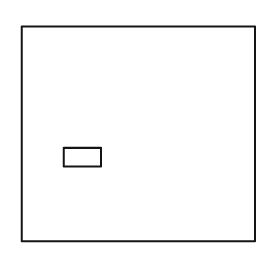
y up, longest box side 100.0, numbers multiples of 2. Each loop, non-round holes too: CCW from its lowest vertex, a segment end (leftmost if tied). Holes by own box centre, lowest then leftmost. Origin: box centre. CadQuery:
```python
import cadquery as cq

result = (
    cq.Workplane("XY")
    .moveTo(-50.0, -46.0)
    .lineTo(50.0, -46.0)
    .lineTo(50.0, 46.0)
    .lineTo(-50.0, 46.0)
    .close()
    .moveTo(-32.0, -14.0)
    .lineTo(-16.0, -14.0)
    .lineTo(-16.0, -6.0)
    .lineTo(-32.0, -6.0)
    .close()
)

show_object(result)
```